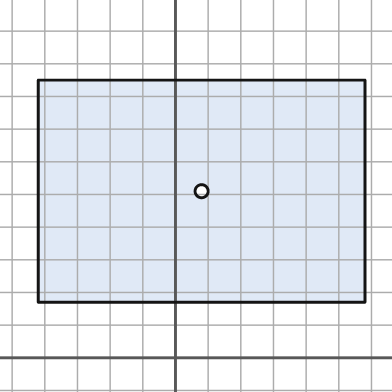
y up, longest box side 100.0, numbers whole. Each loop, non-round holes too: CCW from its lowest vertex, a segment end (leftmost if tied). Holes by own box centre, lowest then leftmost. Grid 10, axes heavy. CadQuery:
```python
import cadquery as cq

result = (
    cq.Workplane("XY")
    .moveTo(-42.0, 17.0)
    .lineTo(58.0, 17.0)
    .lineTo(58.0, 85.0)
    .lineTo(-42.0, 85.0)
    .close()
    .moveTo(8.0, 51.0)
    .circle(2.0)
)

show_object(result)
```